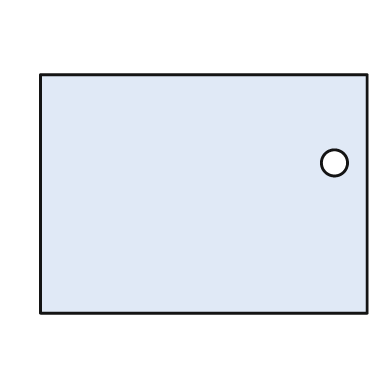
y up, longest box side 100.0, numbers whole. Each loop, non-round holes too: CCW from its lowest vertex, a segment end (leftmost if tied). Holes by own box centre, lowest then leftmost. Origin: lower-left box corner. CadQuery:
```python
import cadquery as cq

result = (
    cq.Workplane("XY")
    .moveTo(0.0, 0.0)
    .lineTo(100.0, 0.0)
    .lineTo(100.0, 73.0)
    .lineTo(0.0, 73.0)
    .close()
    .moveTo(90.0, 46.0)
    .circle(4.0)
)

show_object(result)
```